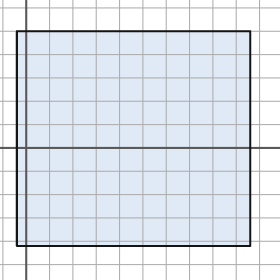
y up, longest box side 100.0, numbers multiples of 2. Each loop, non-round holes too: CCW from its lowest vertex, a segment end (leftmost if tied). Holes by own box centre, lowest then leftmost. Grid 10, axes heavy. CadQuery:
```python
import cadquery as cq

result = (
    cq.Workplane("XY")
    .moveTo(-4.0, -42.0)
    .lineTo(96.0, -42.0)
    .lineTo(96.0, 50.0)
    .lineTo(-4.0, 50.0)
    .close()
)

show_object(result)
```